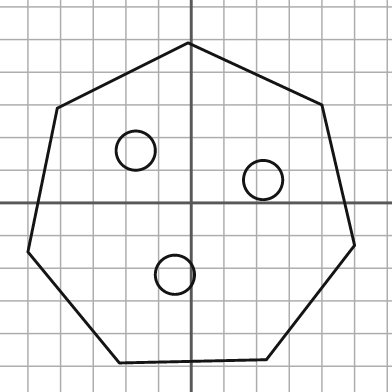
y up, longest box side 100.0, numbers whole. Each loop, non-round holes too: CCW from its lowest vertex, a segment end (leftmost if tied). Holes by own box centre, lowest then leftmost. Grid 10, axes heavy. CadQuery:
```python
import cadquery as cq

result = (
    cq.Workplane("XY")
    .moveTo(-22.0, -49.0)
    .lineTo(23.0, -48.0)
    .lineTo(50.0, -13.0)
    .lineTo(40.0, 30.0)
    .lineTo(-1.0, 49.0)
    .lineTo(-41.0, 29.0)
    .lineTo(-50.0, -15.0)
    .close()
    .moveTo(-5.0, -22.0)
    .circle(6.0)
    .moveTo(22.0, 7.0)
    .circle(6.0)
    .moveTo(-17.0, 16.0)
    .circle(6.0)
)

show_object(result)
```